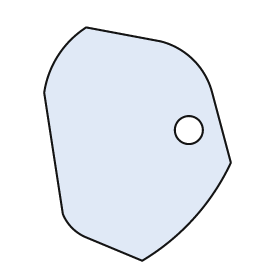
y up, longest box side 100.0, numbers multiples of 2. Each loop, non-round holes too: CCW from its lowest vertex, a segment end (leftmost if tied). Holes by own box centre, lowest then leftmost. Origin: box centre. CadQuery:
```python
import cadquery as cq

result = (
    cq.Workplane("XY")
    .moveTo(2.0, -50.0)
    .threePointArc((24.0, -32.0), (40.0, -8.0))
    .lineTo(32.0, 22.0)
    .threePointArc((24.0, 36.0), (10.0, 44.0))
    .lineTo(-22.0, 50.0)
    .threePointArc((-34.0, 38.0), (-40.0, 22.0))
    .lineTo(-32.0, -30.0)
    .threePointArc((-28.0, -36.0), (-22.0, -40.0))
    .close()
    .moveTo(22.0, 6.0)
    .circle(6.0)
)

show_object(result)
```